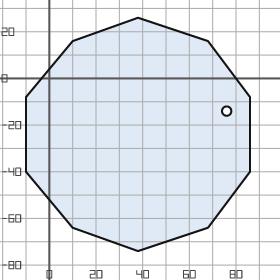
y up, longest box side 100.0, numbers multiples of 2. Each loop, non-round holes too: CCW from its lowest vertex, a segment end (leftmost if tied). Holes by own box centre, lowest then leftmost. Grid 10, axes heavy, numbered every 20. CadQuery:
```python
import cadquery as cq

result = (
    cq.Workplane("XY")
    .moveTo(38.0, -74.0)
    .lineTo(68.0, -64.0)
    .lineTo(86.0, -40.0)
    .lineTo(86.0, -8.0)
    .lineTo(68.0, 16.0)
    .lineTo(38.0, 26.0)
    .lineTo(10.0, 16.0)
    .lineTo(-10.0, -8.0)
    .lineTo(-10.0, -40.0)
    .lineTo(10.0, -64.0)
    .close()
    .moveTo(76.0, -14.0)
    .circle(2.0)
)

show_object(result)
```